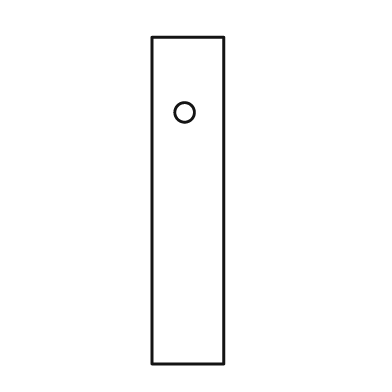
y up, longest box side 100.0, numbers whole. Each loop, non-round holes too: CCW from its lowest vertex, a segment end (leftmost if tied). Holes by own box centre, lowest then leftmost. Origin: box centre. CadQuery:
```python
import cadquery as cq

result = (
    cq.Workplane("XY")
    .moveTo(-11.0, -50.0)
    .lineTo(11.0, -50.0)
    .lineTo(11.0, 50.0)
    .lineTo(-11.0, 50.0)
    .close()
    .moveTo(-1.0, 27.0)
    .circle(3.0)
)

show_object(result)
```